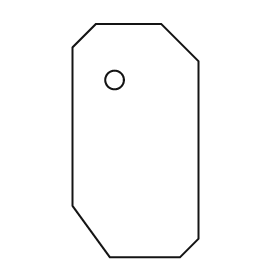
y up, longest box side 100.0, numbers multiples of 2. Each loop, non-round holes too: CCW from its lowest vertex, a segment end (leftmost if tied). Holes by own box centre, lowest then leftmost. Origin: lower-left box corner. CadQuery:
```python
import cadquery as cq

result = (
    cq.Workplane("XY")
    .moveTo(16.0, 0.0)
    .lineTo(46.0, 0.0)
    .lineTo(54.0, 8.0)
    .lineTo(54.0, 84.0)
    .lineTo(38.0, 100.0)
    .lineTo(10.0, 100.0)
    .lineTo(0.0, 90.0)
    .lineTo(0.0, 22.0)
    .close()
    .moveTo(18.0, 76.0)
    .circle(4.0)
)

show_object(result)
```